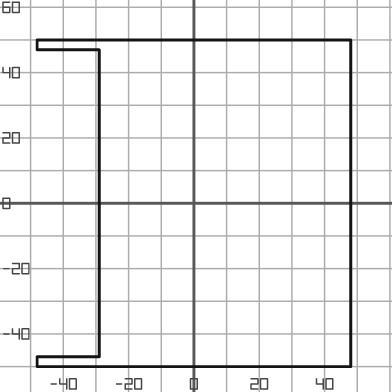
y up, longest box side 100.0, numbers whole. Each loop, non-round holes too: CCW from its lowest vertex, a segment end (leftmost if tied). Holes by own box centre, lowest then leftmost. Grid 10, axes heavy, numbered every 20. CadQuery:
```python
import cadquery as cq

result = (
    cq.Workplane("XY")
    .moveTo(-48.0, -50.0)
    .lineTo(48.0, -50.0)
    .lineTo(48.0, 50.0)
    .lineTo(-48.0, 50.0)
    .lineTo(-48.0, 47.0)
    .lineTo(-29.0, 47.0)
    .lineTo(-29.0, -47.0)
    .lineTo(-48.0, -47.0)
    .close()
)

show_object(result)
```